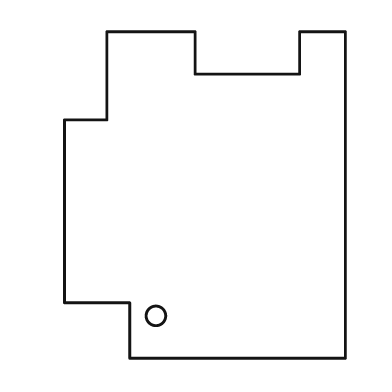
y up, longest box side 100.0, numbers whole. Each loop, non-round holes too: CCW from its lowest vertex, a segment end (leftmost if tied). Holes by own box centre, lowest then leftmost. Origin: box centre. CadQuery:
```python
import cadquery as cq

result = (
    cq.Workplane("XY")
    .moveTo(-23.0, -50.0)
    .lineTo(43.0, -50.0)
    .lineTo(43.0, 50.0)
    .lineTo(29.0, 50.0)
    .lineTo(29.0, 37.0)
    .lineTo(-3.0, 37.0)
    .lineTo(-3.0, 50.0)
    .lineTo(-30.0, 50.0)
    .lineTo(-30.0, 23.0)
    .lineTo(-43.0, 23.0)
    .lineTo(-43.0, -33.0)
    .lineTo(-23.0, -33.0)
    .close()
    .moveTo(-15.0, -37.0)
    .circle(3.0)
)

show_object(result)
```